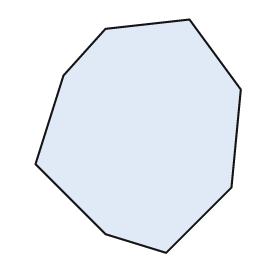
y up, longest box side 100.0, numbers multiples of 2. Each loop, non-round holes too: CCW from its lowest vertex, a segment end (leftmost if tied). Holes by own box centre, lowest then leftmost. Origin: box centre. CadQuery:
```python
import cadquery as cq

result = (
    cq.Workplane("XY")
    .moveTo(12.0, -50.0)
    .lineTo(40.0, -22.0)
    .lineTo(44.0, 20.0)
    .lineTo(22.0, 50.0)
    .lineTo(-14.0, 46.0)
    .lineTo(-32.0, 26.0)
    .lineTo(-44.0, -12.0)
    .lineTo(-14.0, -42.0)
    .close()
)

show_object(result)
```